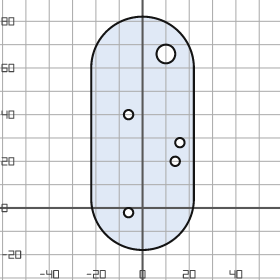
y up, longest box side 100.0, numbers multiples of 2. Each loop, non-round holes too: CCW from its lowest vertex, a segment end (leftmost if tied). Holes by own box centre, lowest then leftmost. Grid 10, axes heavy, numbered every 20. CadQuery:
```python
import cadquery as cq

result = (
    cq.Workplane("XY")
    .moveTo(-22.0, 4.0)
    .threePointArc((0.0, -18.0), (22.0, 4.0))
    .lineTo(22.0, 60.0)
    .threePointArc((0.0, 82.0), (-22.0, 60.0))
    .close()
    .moveTo(-6.0, -2.0)
    .circle(2.0)
    .moveTo(14.0, 20.0)
    .circle(2.0)
    .moveTo(16.0, 28.0)
    .circle(2.0)
    .moveTo(-6.0, 40.0)
    .circle(2.0)
    .moveTo(10.0, 66.0)
    .circle(4.0)
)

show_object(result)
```